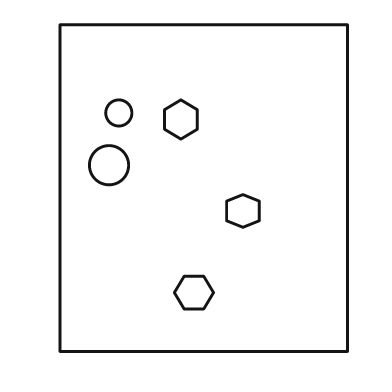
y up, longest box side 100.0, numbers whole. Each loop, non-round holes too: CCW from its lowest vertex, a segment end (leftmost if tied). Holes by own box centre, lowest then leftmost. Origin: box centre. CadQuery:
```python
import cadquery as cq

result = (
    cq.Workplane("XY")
    .moveTo(-44.0, -50.0)
    .lineTo(44.0, -50.0)
    .lineTo(44.0, 50.0)
    .lineTo(-44.0, 50.0)
    .close()
    .moveTo(-6.0, -37.0)
    .lineTo(0.0, -37.0)
    .lineTo(3.0, -32.0)
    .lineTo(0.0, -27.0)
    .lineTo(-6.0, -27.0)
    .lineTo(-9.0, -32.0)
    .close()
    .moveTo(12.0, -12.0)
    .lineTo(17.0, -10.0)
    .lineTo(17.0, -4.0)
    .lineTo(12.0, -2.0)
    .lineTo(7.0, -4.0)
    .lineTo(7.0, -10.0)
    .close()
    .moveTo(-29.0, 7.0)
    .circle(6.0)
    .moveTo(-7.0, 15.0)
    .lineTo(-2.0, 18.0)
    .lineTo(-2.0, 24.0)
    .lineTo(-7.0, 27.0)
    .lineTo(-12.0, 24.0)
    .lineTo(-12.0, 18.0)
    .close()
    .moveTo(-26.0, 23.0)
    .circle(4.0)
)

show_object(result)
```